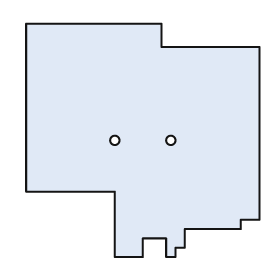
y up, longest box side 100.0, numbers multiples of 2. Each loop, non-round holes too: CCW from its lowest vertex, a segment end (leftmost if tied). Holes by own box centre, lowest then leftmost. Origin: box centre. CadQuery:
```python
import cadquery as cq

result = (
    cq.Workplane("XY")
    .moveTo(-12.0, -50.0)
    .lineTo(0.0, -50.0)
    .lineTo(0.0, -42.0)
    .lineTo(10.0, -42.0)
    .lineTo(10.0, -50.0)
    .lineTo(14.0, -50.0)
    .lineTo(14.0, -46.0)
    .lineTo(18.0, -46.0)
    .lineTo(18.0, -38.0)
    .lineTo(42.0, -38.0)
    .lineTo(42.0, -34.0)
    .lineTo(50.0, -34.0)
    .lineTo(50.0, 40.0)
    .lineTo(8.0, 40.0)
    .lineTo(8.0, 50.0)
    .lineTo(-50.0, 50.0)
    .lineTo(-50.0, -22.0)
    .lineTo(-12.0, -22.0)
    .close()
    .moveTo(-12.0, 0.0)
    .circle(2.0)
    .moveTo(12.0, 0.0)
    .circle(2.0)
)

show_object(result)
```